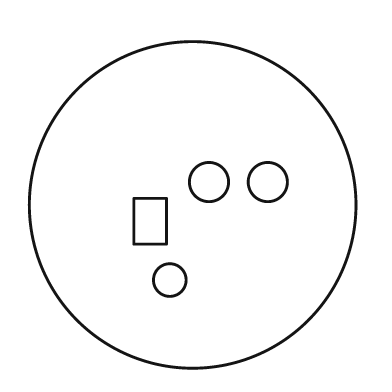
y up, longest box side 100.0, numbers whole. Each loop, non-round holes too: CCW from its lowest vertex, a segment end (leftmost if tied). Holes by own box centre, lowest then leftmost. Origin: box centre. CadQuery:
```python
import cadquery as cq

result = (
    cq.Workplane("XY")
    .moveTo(0.0, 0.0)
    .circle(50.0)
    .moveTo(-7.0, -23.0)
    .circle(5.0)
    .moveTo(-18.0, -12.0)
    .lineTo(-8.0, -12.0)
    .lineTo(-8.0, 2.0)
    .lineTo(-18.0, 2.0)
    .close()
    .moveTo(5.0, 7.0)
    .circle(6.0)
    .moveTo(23.0, 7.0)
    .circle(6.0)
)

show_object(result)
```